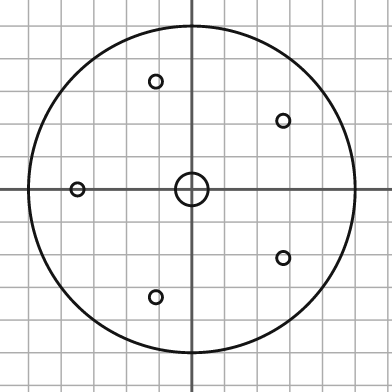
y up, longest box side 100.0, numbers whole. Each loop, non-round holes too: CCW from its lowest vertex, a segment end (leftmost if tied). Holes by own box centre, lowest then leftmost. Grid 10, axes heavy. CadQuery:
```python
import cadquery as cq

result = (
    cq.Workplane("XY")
    .moveTo(0.0, 0.0)
    .circle(50.0)
    .moveTo(-11.0, -33.0)
    .circle(2.0)
    .moveTo(28.0, -21.0)
    .circle(2.0)
    .moveTo(-35.0, 0.0)
    .circle(2.0)
    .moveTo(0.0, 0.0)
    .circle(5.0)
    .moveTo(28.0, 21.0)
    .circle(2.0)
    .moveTo(-11.0, 33.0)
    .circle(2.0)
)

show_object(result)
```